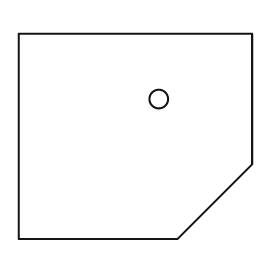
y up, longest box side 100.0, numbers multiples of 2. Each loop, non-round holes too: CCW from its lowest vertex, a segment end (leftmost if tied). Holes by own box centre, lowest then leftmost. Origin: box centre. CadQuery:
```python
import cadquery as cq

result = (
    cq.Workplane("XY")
    .moveTo(-50.0, -44.0)
    .lineTo(18.0, -44.0)
    .lineTo(50.0, -12.0)
    .lineTo(50.0, 44.0)
    .lineTo(-50.0, 44.0)
    .close()
    .moveTo(10.0, 16.0)
    .circle(4.0)
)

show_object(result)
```